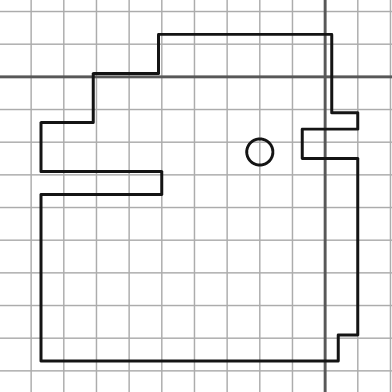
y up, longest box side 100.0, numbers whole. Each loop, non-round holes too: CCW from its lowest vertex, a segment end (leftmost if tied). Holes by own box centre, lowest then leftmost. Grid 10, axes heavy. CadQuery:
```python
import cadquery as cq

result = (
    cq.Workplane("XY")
    .moveTo(-87.0, -87.0)
    .lineTo(4.0, -87.0)
    .lineTo(4.0, -79.0)
    .lineTo(10.0, -79.0)
    .lineTo(10.0, -25.0)
    .lineTo(-7.0, -25.0)
    .lineTo(-7.0, -16.0)
    .lineTo(10.0, -16.0)
    .lineTo(10.0, -11.0)
    .lineTo(2.0, -11.0)
    .lineTo(2.0, 13.0)
    .lineTo(-51.0, 13.0)
    .lineTo(-51.0, 1.0)
    .lineTo(-71.0, 1.0)
    .lineTo(-71.0, -14.0)
    .lineTo(-87.0, -14.0)
    .lineTo(-87.0, -29.0)
    .lineTo(-50.0, -29.0)
    .lineTo(-50.0, -36.0)
    .lineTo(-87.0, -36.0)
    .close()
    .moveTo(-20.0, -23.0)
    .circle(4.0)
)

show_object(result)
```